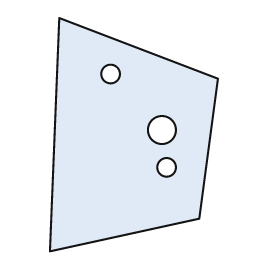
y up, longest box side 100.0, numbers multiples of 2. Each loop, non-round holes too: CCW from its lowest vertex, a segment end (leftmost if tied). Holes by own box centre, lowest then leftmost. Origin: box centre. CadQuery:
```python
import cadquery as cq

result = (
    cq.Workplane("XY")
    .moveTo(-36.0, -50.0)
    .lineTo(28.0, -36.0)
    .lineTo(36.0, 24.0)
    .lineTo(-32.0, 50.0)
    .close()
    .moveTo(14.0, -14.0)
    .circle(4.0)
    .moveTo(12.0, 2.0)
    .circle(6.0)
    .moveTo(-10.0, 26.0)
    .circle(4.0)
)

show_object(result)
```